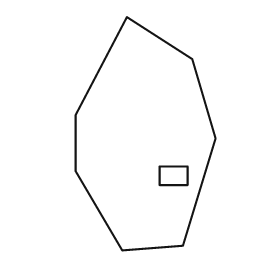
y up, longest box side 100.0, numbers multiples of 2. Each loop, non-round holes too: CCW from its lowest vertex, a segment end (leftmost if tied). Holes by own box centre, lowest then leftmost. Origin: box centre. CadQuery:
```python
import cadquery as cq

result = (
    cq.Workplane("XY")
    .moveTo(-10.0, -50.0)
    .lineTo(16.0, -48.0)
    .lineTo(30.0, -2.0)
    .lineTo(20.0, 32.0)
    .lineTo(-8.0, 50.0)
    .lineTo(-30.0, 8.0)
    .lineTo(-30.0, -16.0)
    .close()
    .moveTo(6.0, -22.0)
    .lineTo(18.0, -22.0)
    .lineTo(18.0, -14.0)
    .lineTo(6.0, -14.0)
    .close()
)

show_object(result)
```